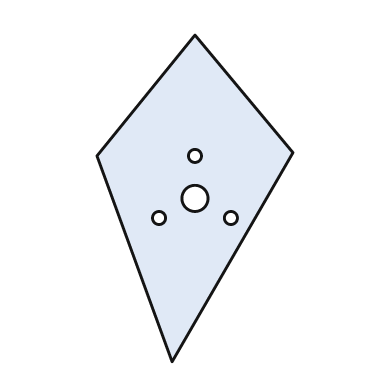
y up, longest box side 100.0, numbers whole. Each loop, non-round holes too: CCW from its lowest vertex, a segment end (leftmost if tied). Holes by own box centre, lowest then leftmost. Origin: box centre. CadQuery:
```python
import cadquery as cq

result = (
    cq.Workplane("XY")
    .moveTo(-7.0, -50.0)
    .lineTo(30.0, 14.0)
    .lineTo(0.0, 50.0)
    .lineTo(-30.0, 13.0)
    .close()
    .moveTo(-11.0, -6.0)
    .circle(2.0)
    .moveTo(11.0, -6.0)
    .circle(2.0)
    .moveTo(0.0, 0.0)
    .circle(4.0)
    .moveTo(0.0, 13.0)
    .circle(2.0)
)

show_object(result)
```